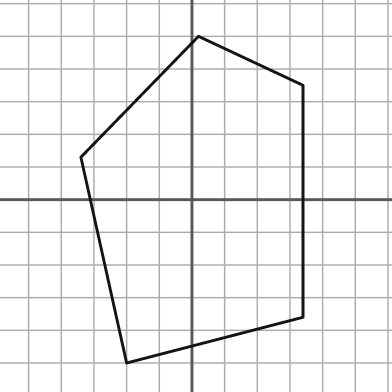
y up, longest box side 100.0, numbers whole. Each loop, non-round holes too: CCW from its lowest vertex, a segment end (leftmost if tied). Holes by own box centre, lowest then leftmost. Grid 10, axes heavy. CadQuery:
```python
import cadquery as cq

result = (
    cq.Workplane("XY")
    .moveTo(-20.0, -50.0)
    .lineTo(34.0, -36.0)
    .lineTo(34.0, 35.0)
    .lineTo(2.0, 50.0)
    .lineTo(-34.0, 13.0)
    .close()
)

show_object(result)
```